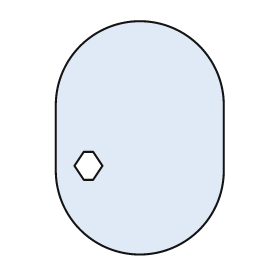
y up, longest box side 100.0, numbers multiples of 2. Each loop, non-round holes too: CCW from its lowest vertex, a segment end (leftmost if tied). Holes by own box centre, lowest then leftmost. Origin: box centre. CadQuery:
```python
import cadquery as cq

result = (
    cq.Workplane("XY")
    .moveTo(-36.0, -14.0)
    .threePointArc((0.0, -50.0), (36.0, -14.0))
    .lineTo(36.0, 14.0)
    .threePointArc((0.0, 50.0), (-36.0, 14.0))
    .close()
    .moveTo(-24.0, -18.0)
    .lineTo(-20.0, -18.0)
    .lineTo(-16.0, -12.0)
    .lineTo(-20.0, -6.0)
    .lineTo(-24.0, -6.0)
    .lineTo(-28.0, -12.0)
    .close()
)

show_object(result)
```